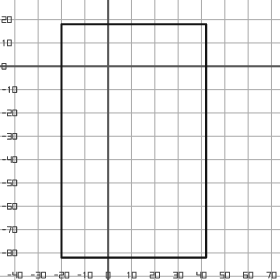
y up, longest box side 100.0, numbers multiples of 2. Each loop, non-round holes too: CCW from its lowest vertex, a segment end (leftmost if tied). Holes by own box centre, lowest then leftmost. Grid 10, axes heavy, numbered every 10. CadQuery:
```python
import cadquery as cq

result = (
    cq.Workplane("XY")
    .moveTo(-20.0, -82.0)
    .lineTo(42.0, -82.0)
    .lineTo(42.0, 18.0)
    .lineTo(-20.0, 18.0)
    .close()
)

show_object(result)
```